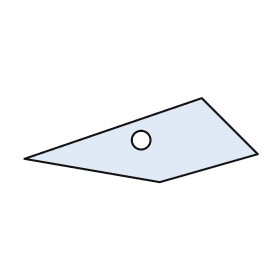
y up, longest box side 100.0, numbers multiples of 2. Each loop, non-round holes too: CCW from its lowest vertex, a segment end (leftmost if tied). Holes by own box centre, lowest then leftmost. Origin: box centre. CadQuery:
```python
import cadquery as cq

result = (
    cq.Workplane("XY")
    .moveTo(8.0, -18.0)
    .lineTo(50.0, -6.0)
    .lineTo(26.0, 18.0)
    .lineTo(-50.0, -8.0)
    .close()
    .moveTo(0.0, 0.0)
    .circle(4.0)
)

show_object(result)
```